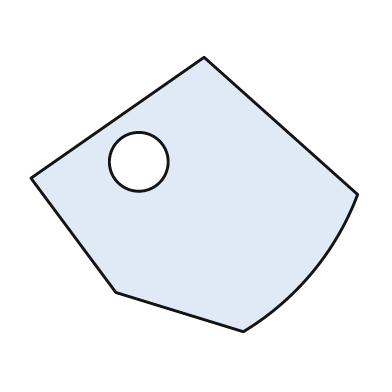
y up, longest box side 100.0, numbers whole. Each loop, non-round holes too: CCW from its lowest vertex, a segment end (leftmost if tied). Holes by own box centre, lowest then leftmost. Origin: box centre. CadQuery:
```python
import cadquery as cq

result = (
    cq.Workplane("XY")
    .moveTo(15.0, -42.0)
    .threePointArc((36.0, -24.0), (50.0, 0.0))
    .lineTo(3.0, 42.0)
    .lineTo(-50.0, 5.0)
    .lineTo(-24.0, -30.0)
    .close()
    .moveTo(-17.0, 10.0)
    .circle(9.0)
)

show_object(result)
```